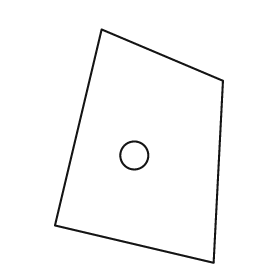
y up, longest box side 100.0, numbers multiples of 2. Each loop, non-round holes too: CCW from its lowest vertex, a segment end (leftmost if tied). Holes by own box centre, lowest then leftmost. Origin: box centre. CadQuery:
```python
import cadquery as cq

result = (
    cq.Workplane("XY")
    .moveTo(32.0, -50.0)
    .lineTo(36.0, 28.0)
    .lineTo(-16.0, 50.0)
    .lineTo(-36.0, -34.0)
    .close()
    .moveTo(-2.0, -4.0)
    .circle(6.0)
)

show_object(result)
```